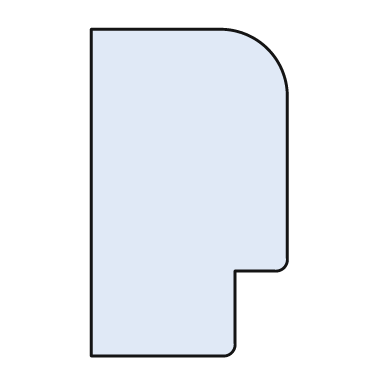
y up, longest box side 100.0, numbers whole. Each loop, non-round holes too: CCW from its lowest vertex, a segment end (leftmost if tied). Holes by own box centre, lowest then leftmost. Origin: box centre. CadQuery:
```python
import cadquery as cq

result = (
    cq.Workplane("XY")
    .moveTo(-30.0, -50.0)
    .lineTo(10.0, -50.0)
    .threePointArc((13.0, -49.0), (14.0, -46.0))
    .lineTo(14.0, -24.0)
    .lineTo(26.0, -24.0)
    .threePointArc((29.0, -23.0), (30.0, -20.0))
    .lineTo(30.0, 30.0)
    .threePointArc((24.0, 44.0), (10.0, 50.0))
    .lineTo(-30.0, 50.0)
    .close()
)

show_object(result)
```